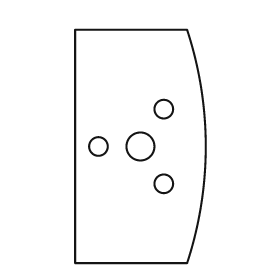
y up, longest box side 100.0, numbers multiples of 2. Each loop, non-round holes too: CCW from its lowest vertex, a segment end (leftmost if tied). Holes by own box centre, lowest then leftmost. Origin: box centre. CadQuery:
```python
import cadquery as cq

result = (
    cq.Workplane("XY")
    .moveTo(-28.0, -50.0)
    .lineTo(20.0, -50.0)
    .threePointArc((28.0, 0.0), (20.0, 50.0))
    .lineTo(-28.0, 50.0)
    .close()
    .moveTo(10.0, -16.0)
    .circle(4.0)
    .moveTo(-18.0, 0.0)
    .circle(4.0)
    .moveTo(0.0, 0.0)
    .circle(6.0)
    .moveTo(10.0, 16.0)
    .circle(4.0)
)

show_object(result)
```